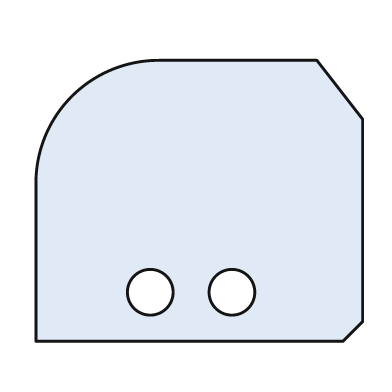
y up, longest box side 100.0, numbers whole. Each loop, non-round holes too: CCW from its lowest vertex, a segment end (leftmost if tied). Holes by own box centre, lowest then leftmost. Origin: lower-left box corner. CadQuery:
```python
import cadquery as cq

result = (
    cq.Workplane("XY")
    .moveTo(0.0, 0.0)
    .lineTo(94.0, 0.0)
    .lineTo(100.0, 6.0)
    .lineTo(100.0, 68.0)
    .lineTo(86.0, 86.0)
    .lineTo(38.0, 86.0)
    .threePointArc((11.0, 75.0), (0.0, 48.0))
    .close()
    .moveTo(35.0, 15.0)
    .circle(7.0)
    .moveTo(60.0, 15.0)
    .circle(7.0)
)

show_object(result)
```